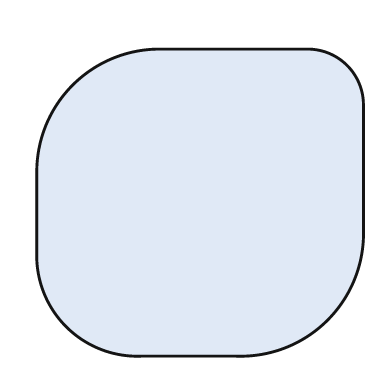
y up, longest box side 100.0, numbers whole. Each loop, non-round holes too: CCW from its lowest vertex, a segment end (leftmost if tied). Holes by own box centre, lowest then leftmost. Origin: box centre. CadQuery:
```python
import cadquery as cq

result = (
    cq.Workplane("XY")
    .moveTo(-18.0, -47.0)
    .lineTo(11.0, -47.0)
    .threePointArc((39.0, -36.0), (50.0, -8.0))
    .lineTo(50.0, 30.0)
    .threePointArc((45.0, 42.0), (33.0, 47.0))
    .lineTo(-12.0, 47.0)
    .threePointArc((-39.0, 36.0), (-50.0, 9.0))
    .lineTo(-50.0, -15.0)
    .threePointArc((-41.0, -38.0), (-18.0, -47.0))
    .close()
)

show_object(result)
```